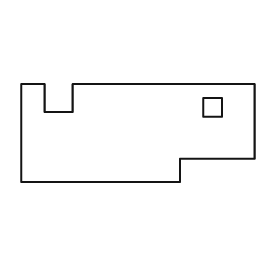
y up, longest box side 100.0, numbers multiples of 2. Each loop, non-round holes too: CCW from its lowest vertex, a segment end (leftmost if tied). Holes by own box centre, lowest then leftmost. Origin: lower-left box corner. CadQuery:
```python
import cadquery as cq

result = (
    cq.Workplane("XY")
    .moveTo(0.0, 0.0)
    .lineTo(68.0, 0.0)
    .lineTo(68.0, 10.0)
    .lineTo(100.0, 10.0)
    .lineTo(100.0, 42.0)
    .lineTo(22.0, 42.0)
    .lineTo(22.0, 30.0)
    .lineTo(10.0, 30.0)
    .lineTo(10.0, 42.0)
    .lineTo(0.0, 42.0)
    .close()
    .moveTo(78.0, 28.0)
    .lineTo(86.0, 28.0)
    .lineTo(86.0, 36.0)
    .lineTo(78.0, 36.0)
    .close()
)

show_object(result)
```